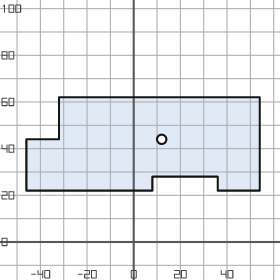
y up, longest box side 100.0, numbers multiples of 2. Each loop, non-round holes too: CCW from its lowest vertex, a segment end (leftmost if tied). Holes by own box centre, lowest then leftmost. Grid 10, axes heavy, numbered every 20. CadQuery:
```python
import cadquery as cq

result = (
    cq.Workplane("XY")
    .moveTo(-46.0, 22.0)
    .lineTo(8.0, 22.0)
    .lineTo(8.0, 28.0)
    .lineTo(36.0, 28.0)
    .lineTo(36.0, 22.0)
    .lineTo(54.0, 22.0)
    .lineTo(54.0, 62.0)
    .lineTo(-32.0, 62.0)
    .lineTo(-32.0, 44.0)
    .lineTo(-46.0, 44.0)
    .close()
    .moveTo(12.0, 44.0)
    .circle(2.0)
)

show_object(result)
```